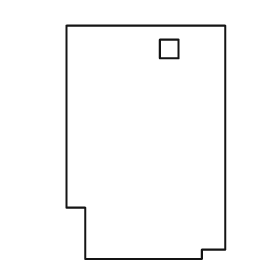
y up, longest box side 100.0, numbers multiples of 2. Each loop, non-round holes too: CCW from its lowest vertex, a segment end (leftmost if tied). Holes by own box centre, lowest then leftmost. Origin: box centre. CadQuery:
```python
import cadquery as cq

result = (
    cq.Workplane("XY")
    .moveTo(-26.0, -50.0)
    .lineTo(24.0, -50.0)
    .lineTo(24.0, -46.0)
    .lineTo(34.0, -46.0)
    .lineTo(34.0, 50.0)
    .lineTo(-34.0, 50.0)
    .lineTo(-34.0, -28.0)
    .lineTo(-26.0, -28.0)
    .close()
    .moveTo(6.0, 36.0)
    .lineTo(14.0, 36.0)
    .lineTo(14.0, 44.0)
    .lineTo(6.0, 44.0)
    .close()
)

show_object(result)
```